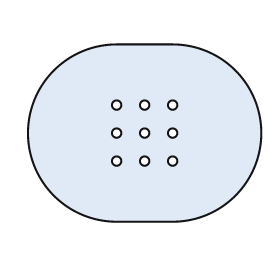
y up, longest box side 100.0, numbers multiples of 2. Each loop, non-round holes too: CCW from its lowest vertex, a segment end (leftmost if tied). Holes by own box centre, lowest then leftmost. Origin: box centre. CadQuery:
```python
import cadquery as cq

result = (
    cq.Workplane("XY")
    .moveTo(-12.0, -38.0)
    .lineTo(12.0, -38.0)
    .threePointArc((50.0, 0.0), (12.0, 38.0))
    .lineTo(-12.0, 38.0)
    .threePointArc((-50.0, 0.0), (-12.0, -38.0))
    .close()
    .moveTo(-12.0, -12.0)
    .circle(2.0)
    .moveTo(0.0, -12.0)
    .circle(2.0)
    .moveTo(12.0, -12.0)
    .circle(2.0)
    .moveTo(-12.0, 0.0)
    .circle(2.0)
    .moveTo(0.0, 0.0)
    .circle(2.0)
    .moveTo(12.0, 0.0)
    .circle(2.0)
    .moveTo(-12.0, 12.0)
    .circle(2.0)
    .moveTo(0.0, 12.0)
    .circle(2.0)
    .moveTo(12.0, 12.0)
    .circle(2.0)
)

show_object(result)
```